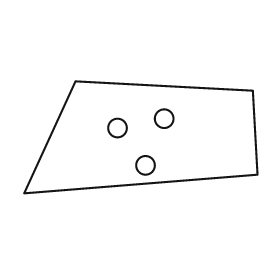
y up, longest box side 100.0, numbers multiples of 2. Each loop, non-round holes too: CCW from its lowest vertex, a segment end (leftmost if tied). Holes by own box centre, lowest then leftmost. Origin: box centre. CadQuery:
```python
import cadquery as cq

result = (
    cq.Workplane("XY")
    .moveTo(-50.0, -24.0)
    .lineTo(50.0, -16.0)
    .lineTo(48.0, 20.0)
    .lineTo(-28.0, 24.0)
    .close()
    .moveTo(2.0, -12.0)
    .circle(4.0)
    .moveTo(-10.0, 4.0)
    .circle(4.0)
    .moveTo(10.0, 8.0)
    .circle(4.0)
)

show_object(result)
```